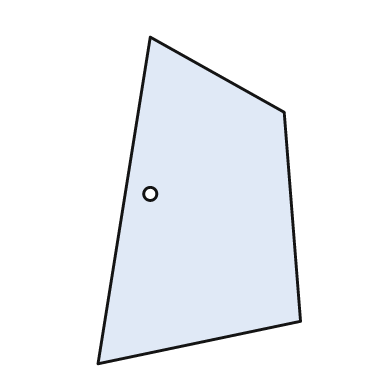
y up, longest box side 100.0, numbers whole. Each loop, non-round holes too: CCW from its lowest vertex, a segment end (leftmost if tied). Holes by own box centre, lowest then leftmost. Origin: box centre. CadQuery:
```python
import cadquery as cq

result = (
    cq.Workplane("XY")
    .moveTo(-31.0, -50.0)
    .lineTo(31.0, -37.0)
    .lineTo(26.0, 27.0)
    .lineTo(-15.0, 50.0)
    .close()
    .moveTo(-15.0, 2.0)
    .circle(2.0)
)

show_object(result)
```